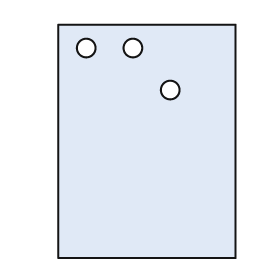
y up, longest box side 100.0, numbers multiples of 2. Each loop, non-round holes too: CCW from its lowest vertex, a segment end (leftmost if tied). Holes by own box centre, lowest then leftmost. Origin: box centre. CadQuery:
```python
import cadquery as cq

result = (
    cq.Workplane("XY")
    .moveTo(-38.0, -50.0)
    .lineTo(38.0, -50.0)
    .lineTo(38.0, 50.0)
    .lineTo(-38.0, 50.0)
    .close()
    .moveTo(10.0, 22.0)
    .circle(4.0)
    .moveTo(-26.0, 40.0)
    .circle(4.0)
    .moveTo(-6.0, 40.0)
    .circle(4.0)
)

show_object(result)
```